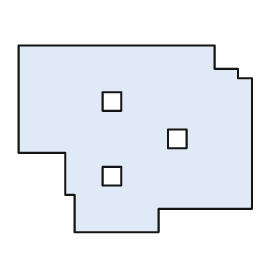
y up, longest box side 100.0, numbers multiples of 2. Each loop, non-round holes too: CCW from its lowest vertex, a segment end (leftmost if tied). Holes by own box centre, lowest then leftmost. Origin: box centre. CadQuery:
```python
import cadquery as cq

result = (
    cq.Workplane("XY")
    .moveTo(-26.0, -40.0)
    .lineTo(10.0, -40.0)
    .lineTo(10.0, -30.0)
    .lineTo(50.0, -30.0)
    .lineTo(50.0, 26.0)
    .lineTo(44.0, 26.0)
    .lineTo(44.0, 30.0)
    .lineTo(34.0, 30.0)
    .lineTo(34.0, 40.0)
    .lineTo(-50.0, 40.0)
    .lineTo(-50.0, -6.0)
    .lineTo(-30.0, -6.0)
    .lineTo(-30.0, -24.0)
    .lineTo(-26.0, -24.0)
    .close()
    .moveTo(-14.0, -20.0)
    .lineTo(-6.0, -20.0)
    .lineTo(-6.0, -12.0)
    .lineTo(-14.0, -12.0)
    .close()
    .moveTo(14.0, -4.0)
    .lineTo(22.0, -4.0)
    .lineTo(22.0, 4.0)
    .lineTo(14.0, 4.0)
    .close()
    .moveTo(-14.0, 12.0)
    .lineTo(-6.0, 12.0)
    .lineTo(-6.0, 20.0)
    .lineTo(-14.0, 20.0)
    .close()
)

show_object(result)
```